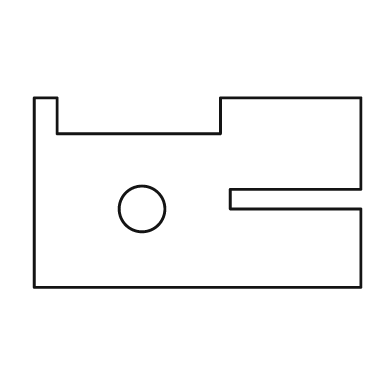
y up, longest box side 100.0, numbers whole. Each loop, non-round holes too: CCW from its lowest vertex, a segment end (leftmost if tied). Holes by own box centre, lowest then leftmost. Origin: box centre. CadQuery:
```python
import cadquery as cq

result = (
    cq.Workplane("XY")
    .moveTo(-50.0, -29.0)
    .lineTo(50.0, -29.0)
    .lineTo(50.0, -5.0)
    .lineTo(10.0, -5.0)
    .lineTo(10.0, 1.0)
    .lineTo(50.0, 1.0)
    .lineTo(50.0, 29.0)
    .lineTo(7.0, 29.0)
    .lineTo(7.0, 18.0)
    .lineTo(-43.0, 18.0)
    .lineTo(-43.0, 29.0)
    .lineTo(-50.0, 29.0)
    .close()
    .moveTo(-17.0, -5.0)
    .circle(7.0)
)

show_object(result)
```